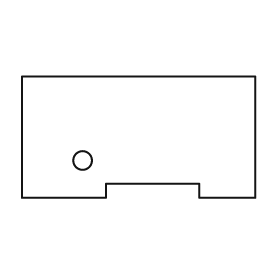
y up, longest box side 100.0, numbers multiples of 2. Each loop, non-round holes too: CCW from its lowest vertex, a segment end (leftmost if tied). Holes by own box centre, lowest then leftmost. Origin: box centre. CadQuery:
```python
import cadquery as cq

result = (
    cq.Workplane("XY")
    .moveTo(-50.0, -26.0)
    .lineTo(-14.0, -26.0)
    .lineTo(-14.0, -20.0)
    .lineTo(26.0, -20.0)
    .lineTo(26.0, -26.0)
    .lineTo(50.0, -26.0)
    .lineTo(50.0, 26.0)
    .lineTo(-50.0, 26.0)
    .close()
    .moveTo(-24.0, -10.0)
    .circle(4.0)
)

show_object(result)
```